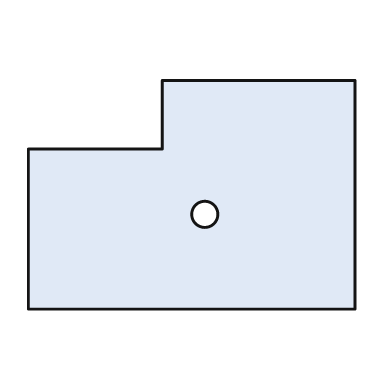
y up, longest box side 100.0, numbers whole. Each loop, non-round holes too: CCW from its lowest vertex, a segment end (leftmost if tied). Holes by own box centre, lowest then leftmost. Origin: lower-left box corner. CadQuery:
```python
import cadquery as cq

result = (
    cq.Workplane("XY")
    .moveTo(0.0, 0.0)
    .lineTo(100.0, 0.0)
    .lineTo(100.0, 70.0)
    .lineTo(41.0, 70.0)
    .lineTo(41.0, 49.0)
    .lineTo(0.0, 49.0)
    .close()
    .moveTo(54.0, 29.0)
    .circle(4.0)
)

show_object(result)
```